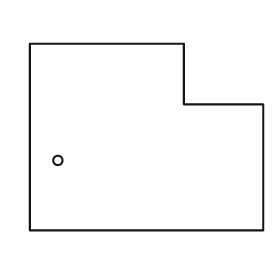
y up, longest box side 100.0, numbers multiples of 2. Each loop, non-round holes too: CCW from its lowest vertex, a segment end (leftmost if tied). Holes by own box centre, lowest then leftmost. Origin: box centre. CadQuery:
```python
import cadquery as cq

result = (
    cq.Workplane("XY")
    .moveTo(-50.0, -40.0)
    .lineTo(50.0, -40.0)
    .lineTo(50.0, 14.0)
    .lineTo(16.0, 14.0)
    .lineTo(16.0, 40.0)
    .lineTo(-50.0, 40.0)
    .close()
    .moveTo(-38.0, -10.0)
    .circle(2.0)
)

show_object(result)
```